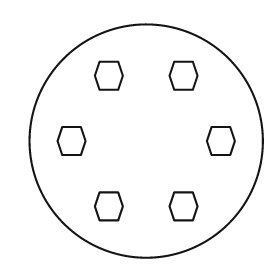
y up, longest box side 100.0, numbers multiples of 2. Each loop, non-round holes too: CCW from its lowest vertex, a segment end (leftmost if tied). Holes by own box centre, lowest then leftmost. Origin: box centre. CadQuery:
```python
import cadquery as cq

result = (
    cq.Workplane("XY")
    .moveTo(0.0, 0.0)
    .circle(50.0)
    .moveTo(-20.0, -34.0)
    .lineTo(-12.0, -34.0)
    .lineTo(-10.0, -28.0)
    .lineTo(-12.0, -22.0)
    .lineTo(-20.0, -22.0)
    .lineTo(-22.0, -28.0)
    .close()
    .moveTo(12.0, -34.0)
    .lineTo(20.0, -34.0)
    .lineTo(22.0, -28.0)
    .lineTo(20.0, -22.0)
    .lineTo(12.0, -22.0)
    .lineTo(10.0, -28.0)
    .close()
    .moveTo(-36.0, -6.0)
    .lineTo(-28.0, -6.0)
    .lineTo(-26.0, 0.0)
    .lineTo(-28.0, 6.0)
    .lineTo(-36.0, 6.0)
    .lineTo(-38.0, 0.0)
    .close()
    .moveTo(28.0, -6.0)
    .lineTo(36.0, -6.0)
    .lineTo(38.0, 0.0)
    .lineTo(36.0, 6.0)
    .lineTo(28.0, 6.0)
    .lineTo(26.0, 0.0)
    .close()
    .moveTo(-20.0, 22.0)
    .lineTo(-12.0, 22.0)
    .lineTo(-10.0, 28.0)
    .lineTo(-12.0, 34.0)
    .lineTo(-20.0, 34.0)
    .lineTo(-22.0, 28.0)
    .close()
    .moveTo(12.0, 22.0)
    .lineTo(20.0, 22.0)
    .lineTo(22.0, 28.0)
    .lineTo(20.0, 34.0)
    .lineTo(12.0, 34.0)
    .lineTo(10.0, 28.0)
    .close()
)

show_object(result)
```